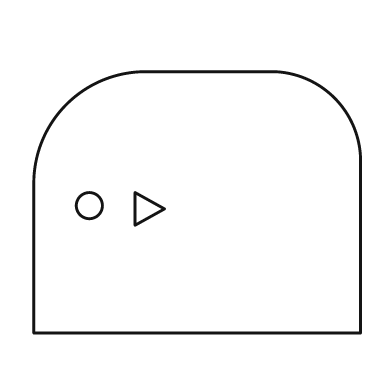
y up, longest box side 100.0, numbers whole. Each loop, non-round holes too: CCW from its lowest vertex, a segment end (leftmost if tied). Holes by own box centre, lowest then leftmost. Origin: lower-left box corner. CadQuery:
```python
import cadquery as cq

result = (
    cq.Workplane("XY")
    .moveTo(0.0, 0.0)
    .lineTo(100.0, 0.0)
    .lineTo(100.0, 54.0)
    .threePointArc((92.0, 72.0), (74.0, 80.0))
    .lineTo(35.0, 80.0)
    .threePointArc((10.0, 70.0), (0.0, 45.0))
    .close()
    .moveTo(31.0, 33.0)
    .lineTo(40.0, 38.0)
    .lineTo(31.0, 43.0)
    .close()
    .moveTo(17.0, 39.0)
    .circle(4.0)
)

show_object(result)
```